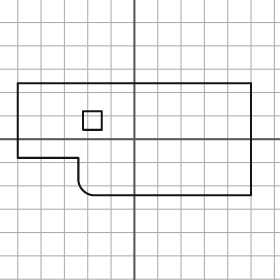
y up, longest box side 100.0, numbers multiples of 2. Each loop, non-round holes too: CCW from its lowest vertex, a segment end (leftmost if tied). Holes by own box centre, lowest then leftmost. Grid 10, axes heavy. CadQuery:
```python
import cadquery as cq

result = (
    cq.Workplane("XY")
    .moveTo(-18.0, -24.0)
    .lineTo(50.0, -24.0)
    .lineTo(50.0, 24.0)
    .lineTo(-50.0, 24.0)
    .lineTo(-50.0, -8.0)
    .lineTo(-24.0, -8.0)
    .lineTo(-24.0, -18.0)
    .threePointArc((-22.0, -22.0), (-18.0, -24.0))
    .close()
    .moveTo(-22.0, 4.0)
    .lineTo(-14.0, 4.0)
    .lineTo(-14.0, 12.0)
    .lineTo(-22.0, 12.0)
    .close()
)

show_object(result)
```